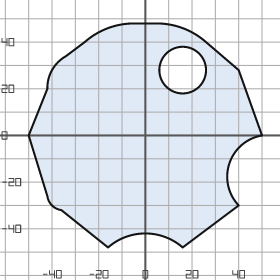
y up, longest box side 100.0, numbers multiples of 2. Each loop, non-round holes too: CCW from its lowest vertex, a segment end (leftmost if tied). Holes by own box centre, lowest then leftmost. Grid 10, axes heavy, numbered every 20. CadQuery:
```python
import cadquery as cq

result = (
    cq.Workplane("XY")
    .moveTo(-16.0, -48.0)
    .threePointArc((0.0, -42.0), (16.0, -48.0))
    .lineTo(40.0, -30.0)
    .threePointArc((36.0, -12.0), (50.0, 0.0))
    .lineTo(40.0, 28.0)
    .lineTo(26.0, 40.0)
    .threePointArc((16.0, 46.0), (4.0, 48.0))
    .lineTo(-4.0, 48.0)
    .threePointArc((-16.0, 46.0), (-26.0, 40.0))
    .lineTo(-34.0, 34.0)
    .threePointArc((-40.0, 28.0), (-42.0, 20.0))
    .lineTo(-50.0, 0.0)
    .lineTo(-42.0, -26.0)
    .threePointArc((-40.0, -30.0), (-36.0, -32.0))
    .close()
    .moveTo(16.0, 28.0)
    .circle(10.0)
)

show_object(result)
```